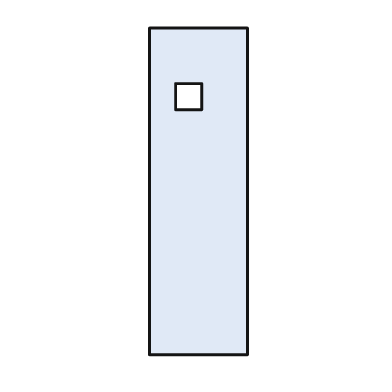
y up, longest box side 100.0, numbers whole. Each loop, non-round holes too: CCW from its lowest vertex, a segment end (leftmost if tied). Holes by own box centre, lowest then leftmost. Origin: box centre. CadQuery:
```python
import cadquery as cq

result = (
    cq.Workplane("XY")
    .moveTo(-15.0, -50.0)
    .lineTo(15.0, -50.0)
    .lineTo(15.0, 50.0)
    .lineTo(-15.0, 50.0)
    .close()
    .moveTo(-7.0, 25.0)
    .lineTo(1.0, 25.0)
    .lineTo(1.0, 33.0)
    .lineTo(-7.0, 33.0)
    .close()
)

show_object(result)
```